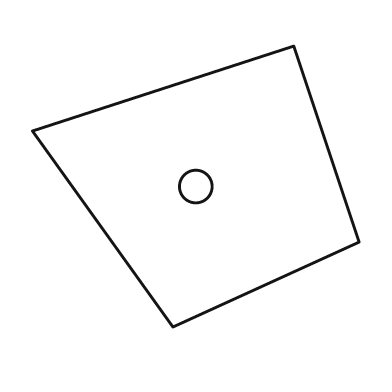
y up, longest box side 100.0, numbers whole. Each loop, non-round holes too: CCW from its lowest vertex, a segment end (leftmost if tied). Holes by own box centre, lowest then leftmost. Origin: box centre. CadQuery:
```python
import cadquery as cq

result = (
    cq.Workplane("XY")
    .moveTo(-7.0, -43.0)
    .lineTo(50.0, -17.0)
    .lineTo(30.0, 43.0)
    .lineTo(-50.0, 17.0)
    .close()
    .moveTo(0.0, 0.0)
    .circle(5.0)
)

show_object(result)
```